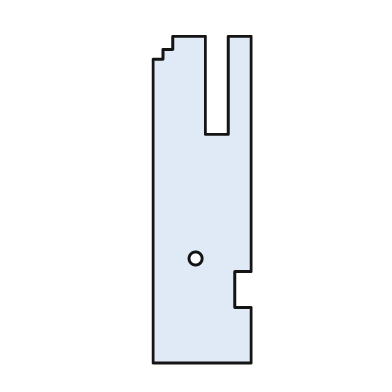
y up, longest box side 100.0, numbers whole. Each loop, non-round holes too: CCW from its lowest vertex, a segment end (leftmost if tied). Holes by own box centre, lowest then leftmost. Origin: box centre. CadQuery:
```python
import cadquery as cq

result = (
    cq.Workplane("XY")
    .moveTo(-15.0, -50.0)
    .lineTo(15.0, -50.0)
    .lineTo(15.0, -33.0)
    .lineTo(10.0, -33.0)
    .lineTo(10.0, -22.0)
    .lineTo(15.0, -22.0)
    .lineTo(15.0, 50.0)
    .lineTo(8.0, 50.0)
    .lineTo(8.0, 20.0)
    .lineTo(1.0, 20.0)
    .lineTo(1.0, 50.0)
    .lineTo(-9.0, 50.0)
    .lineTo(-9.0, 46.0)
    .lineTo(-12.0, 46.0)
    .lineTo(-12.0, 43.0)
    .lineTo(-15.0, 43.0)
    .close()
    .moveTo(-2.0, -18.0)
    .circle(2.0)
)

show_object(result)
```